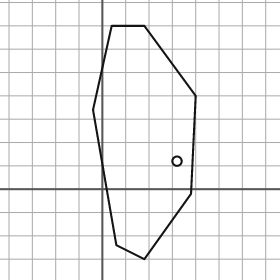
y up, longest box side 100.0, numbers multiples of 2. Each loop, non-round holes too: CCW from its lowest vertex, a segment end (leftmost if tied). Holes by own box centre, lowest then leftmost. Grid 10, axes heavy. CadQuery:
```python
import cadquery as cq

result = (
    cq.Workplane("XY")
    .moveTo(18.0, -30.0)
    .lineTo(38.0, -2.0)
    .lineTo(40.0, 40.0)
    .lineTo(18.0, 70.0)
    .lineTo(4.0, 70.0)
    .lineTo(-4.0, 34.0)
    .lineTo(6.0, -24.0)
    .close()
    .moveTo(32.0, 12.0)
    .circle(2.0)
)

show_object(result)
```